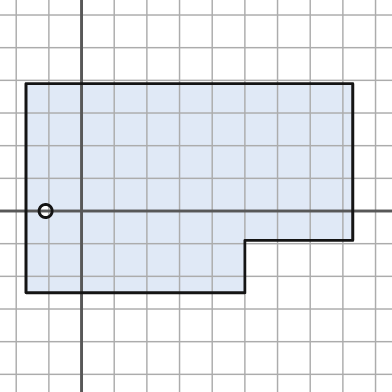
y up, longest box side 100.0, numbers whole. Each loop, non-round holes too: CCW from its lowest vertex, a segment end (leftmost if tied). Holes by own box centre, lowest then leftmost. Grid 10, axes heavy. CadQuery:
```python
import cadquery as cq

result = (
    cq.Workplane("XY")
    .moveTo(-17.0, -25.0)
    .lineTo(50.0, -25.0)
    .lineTo(50.0, -9.0)
    .lineTo(83.0, -9.0)
    .lineTo(83.0, 39.0)
    .lineTo(-17.0, 39.0)
    .close()
    .moveTo(-11.0, 0.0)
    .circle(2.0)
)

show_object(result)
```